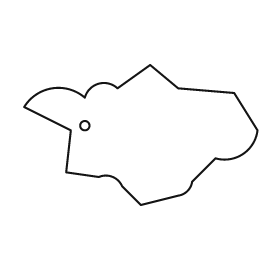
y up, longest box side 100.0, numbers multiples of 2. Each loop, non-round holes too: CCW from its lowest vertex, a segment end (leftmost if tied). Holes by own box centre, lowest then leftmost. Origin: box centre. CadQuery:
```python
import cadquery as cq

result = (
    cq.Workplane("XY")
    .moveTo(0.0, -30.0)
    .lineTo(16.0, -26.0)
    .threePointArc((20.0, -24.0), (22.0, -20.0))
    .lineTo(32.0, -10.0)
    .threePointArc((44.0, -8.0), (50.0, 2.0))
    .lineTo(40.0, 18.0)
    .lineTo(16.0, 20.0)
    .lineTo(4.0, 30.0)
    .lineTo(-10.0, 20.0)
    .threePointArc((-18.0, 22.0), (-24.0, 16.0))
    .threePointArc((-38.0, 20.0), (-50.0, 12.0))
    .lineTo(-30.0, 2.0)
    .lineTo(-32.0, -16.0)
    .lineTo(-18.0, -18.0)
    .threePointArc((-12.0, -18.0), (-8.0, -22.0))
    .close()
    .moveTo(-24.0, 4.0)
    .circle(2.0)
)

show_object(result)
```